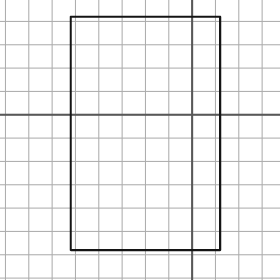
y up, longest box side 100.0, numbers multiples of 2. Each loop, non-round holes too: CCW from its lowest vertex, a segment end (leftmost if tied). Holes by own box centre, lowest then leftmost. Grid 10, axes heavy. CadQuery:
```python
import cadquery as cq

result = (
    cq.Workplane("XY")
    .moveTo(-52.0, -58.0)
    .lineTo(12.0, -58.0)
    .lineTo(12.0, 42.0)
    .lineTo(-52.0, 42.0)
    .close()
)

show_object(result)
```